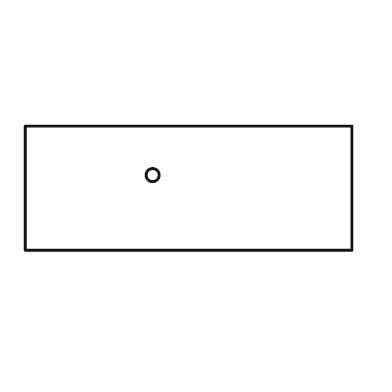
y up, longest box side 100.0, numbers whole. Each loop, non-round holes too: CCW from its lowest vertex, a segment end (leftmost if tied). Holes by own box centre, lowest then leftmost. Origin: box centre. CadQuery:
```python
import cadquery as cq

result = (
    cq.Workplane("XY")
    .moveTo(-50.0, -19.0)
    .lineTo(50.0, -19.0)
    .lineTo(50.0, 19.0)
    .lineTo(-50.0, 19.0)
    .close()
    .moveTo(-11.0, 4.0)
    .circle(2.0)
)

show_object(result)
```